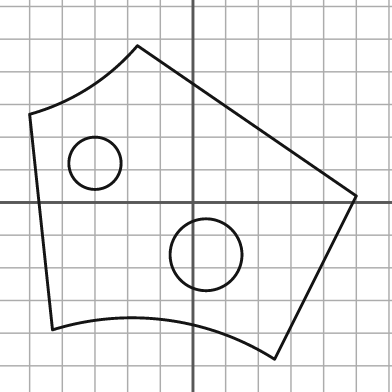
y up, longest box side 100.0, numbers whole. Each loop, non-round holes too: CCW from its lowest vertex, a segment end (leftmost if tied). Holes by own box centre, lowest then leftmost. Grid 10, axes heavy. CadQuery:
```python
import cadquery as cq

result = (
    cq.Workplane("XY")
    .moveTo(25.0, -48.0)
    .lineTo(50.0, 2.0)
    .lineTo(-17.0, 48.0)
    .threePointArc((-32.0, 35.0), (-50.0, 27.0))
    .lineTo(-43.0, -39.0)
    .threePointArc((-8.0, -36.0), (25.0, -48.0))
    .close()
    .moveTo(4.0, -16.0)
    .circle(11.0)
    .moveTo(-30.0, 12.0)
    .circle(8.0)
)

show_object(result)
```